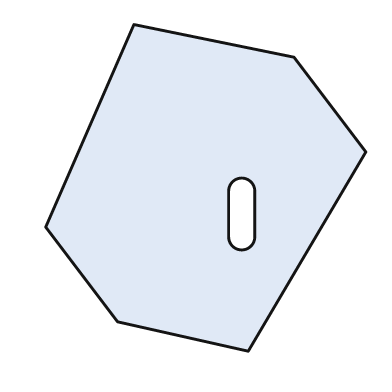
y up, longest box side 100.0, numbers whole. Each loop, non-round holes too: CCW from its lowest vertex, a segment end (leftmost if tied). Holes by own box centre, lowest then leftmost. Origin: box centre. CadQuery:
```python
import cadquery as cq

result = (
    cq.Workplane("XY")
    .moveTo(13.0, -50.0)
    .lineTo(49.0, 11.0)
    .lineTo(27.0, 40.0)
    .lineTo(-22.0, 50.0)
    .lineTo(-49.0, -12.0)
    .lineTo(-27.0, -41.0)
    .close()
    .moveTo(7.0, -15.0)
    .threePointArc((11.0, -19.0), (15.0, -15.0))
    .lineTo(15.0, -1.0)
    .threePointArc((11.0, 3.0), (7.0, -1.0))
    .close()
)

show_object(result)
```